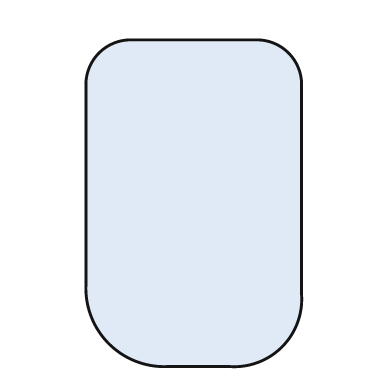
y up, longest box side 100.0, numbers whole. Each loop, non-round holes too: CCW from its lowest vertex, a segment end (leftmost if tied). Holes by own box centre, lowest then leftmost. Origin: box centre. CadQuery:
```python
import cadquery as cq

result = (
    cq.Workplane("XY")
    .moveTo(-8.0, -50.0)
    .lineTo(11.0, -50.0)
    .threePointArc((27.0, -44.0), (33.0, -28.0))
    .lineTo(33.0, 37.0)
    .threePointArc((29.0, 46.0), (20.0, 50.0))
    .lineTo(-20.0, 50.0)
    .threePointArc((-29.0, 46.0), (-33.0, 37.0))
    .lineTo(-33.0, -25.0)
    .threePointArc((-26.0, -43.0), (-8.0, -50.0))
    .close()
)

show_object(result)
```